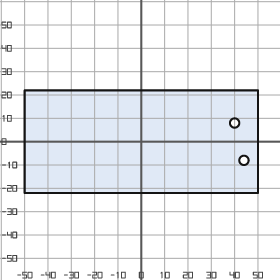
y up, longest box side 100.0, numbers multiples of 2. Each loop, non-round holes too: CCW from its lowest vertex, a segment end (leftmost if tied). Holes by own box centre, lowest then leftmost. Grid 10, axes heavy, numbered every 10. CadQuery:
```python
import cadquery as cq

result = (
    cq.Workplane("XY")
    .moveTo(-50.0, -22.0)
    .lineTo(50.0, -22.0)
    .lineTo(50.0, 22.0)
    .lineTo(-50.0, 22.0)
    .close()
    .moveTo(44.0, -8.0)
    .circle(2.0)
    .moveTo(40.0, 8.0)
    .circle(2.0)
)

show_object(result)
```